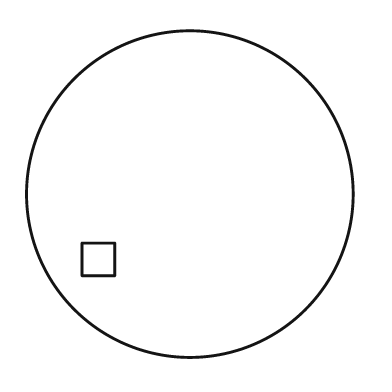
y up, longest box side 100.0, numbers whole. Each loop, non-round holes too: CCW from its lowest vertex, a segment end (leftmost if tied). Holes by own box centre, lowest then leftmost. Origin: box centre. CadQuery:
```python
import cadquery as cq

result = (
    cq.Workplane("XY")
    .moveTo(0.0, 0.0)
    .circle(50.0)
    .moveTo(-33.0, -25.0)
    .lineTo(-23.0, -25.0)
    .lineTo(-23.0, -15.0)
    .lineTo(-33.0, -15.0)
    .close()
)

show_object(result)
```